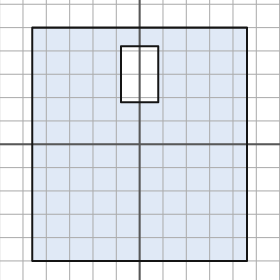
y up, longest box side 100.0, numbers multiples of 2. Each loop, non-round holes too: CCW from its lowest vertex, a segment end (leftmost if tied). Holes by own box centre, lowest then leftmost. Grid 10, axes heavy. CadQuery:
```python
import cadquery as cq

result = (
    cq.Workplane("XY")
    .moveTo(-46.0, -50.0)
    .lineTo(46.0, -50.0)
    .lineTo(46.0, 50.0)
    .lineTo(-46.0, 50.0)
    .close()
    .moveTo(-8.0, 18.0)
    .lineTo(8.0, 18.0)
    .lineTo(8.0, 42.0)
    .lineTo(-8.0, 42.0)
    .close()
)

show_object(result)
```